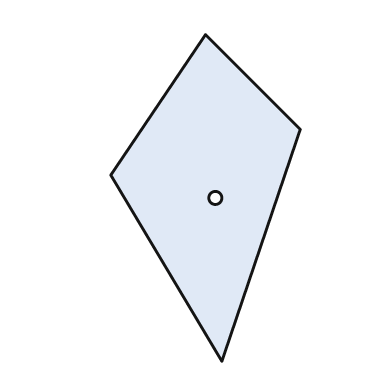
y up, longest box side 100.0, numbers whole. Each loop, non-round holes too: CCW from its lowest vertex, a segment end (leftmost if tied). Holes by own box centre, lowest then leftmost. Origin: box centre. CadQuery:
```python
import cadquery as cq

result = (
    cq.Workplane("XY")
    .moveTo(5.0, -50.0)
    .lineTo(29.0, 21.0)
    .lineTo(0.0, 50.0)
    .lineTo(-29.0, 7.0)
    .close()
    .moveTo(3.0, 0.0)
    .circle(2.0)
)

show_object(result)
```